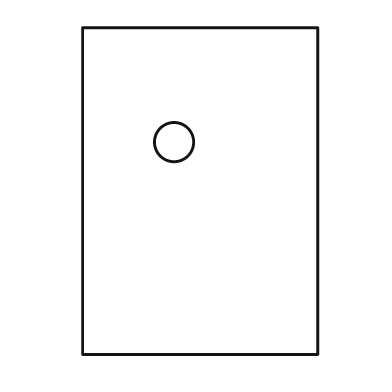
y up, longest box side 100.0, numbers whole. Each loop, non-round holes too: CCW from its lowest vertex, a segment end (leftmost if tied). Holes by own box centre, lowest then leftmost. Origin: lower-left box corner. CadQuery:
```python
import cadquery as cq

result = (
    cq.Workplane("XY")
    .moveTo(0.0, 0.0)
    .lineTo(72.0, 0.0)
    .lineTo(72.0, 100.0)
    .lineTo(0.0, 100.0)
    .close()
    .moveTo(28.0, 65.0)
    .circle(6.0)
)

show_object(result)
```